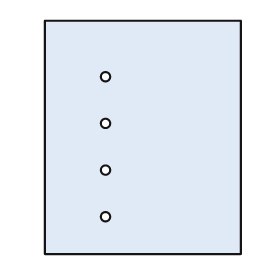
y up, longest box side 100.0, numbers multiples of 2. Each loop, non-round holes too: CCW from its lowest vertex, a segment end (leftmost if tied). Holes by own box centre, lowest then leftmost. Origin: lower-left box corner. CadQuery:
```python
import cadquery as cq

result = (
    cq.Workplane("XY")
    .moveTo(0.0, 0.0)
    .lineTo(84.0, 0.0)
    .lineTo(84.0, 100.0)
    .lineTo(0.0, 100.0)
    .close()
    .moveTo(26.0, 16.0)
    .circle(2.0)
    .moveTo(26.0, 36.0)
    .circle(2.0)
    .moveTo(26.0, 56.0)
    .circle(2.0)
    .moveTo(26.0, 76.0)
    .circle(2.0)
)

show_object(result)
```